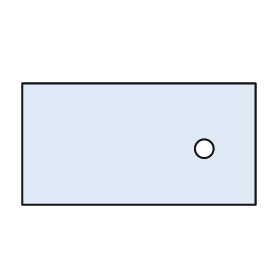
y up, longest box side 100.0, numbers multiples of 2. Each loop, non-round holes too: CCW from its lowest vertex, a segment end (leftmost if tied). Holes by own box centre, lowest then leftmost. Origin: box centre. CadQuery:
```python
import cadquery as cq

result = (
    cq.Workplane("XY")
    .moveTo(-50.0, -26.0)
    .lineTo(50.0, -26.0)
    .lineTo(50.0, 26.0)
    .lineTo(-50.0, 26.0)
    .close()
    .moveTo(28.0, -2.0)
    .circle(4.0)
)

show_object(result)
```